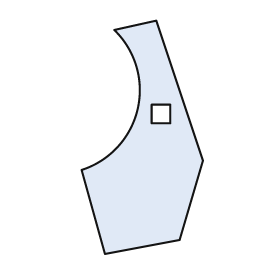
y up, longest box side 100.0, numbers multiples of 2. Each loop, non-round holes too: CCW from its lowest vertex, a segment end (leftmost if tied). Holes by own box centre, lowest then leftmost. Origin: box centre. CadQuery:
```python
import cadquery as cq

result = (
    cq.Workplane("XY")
    .moveTo(-16.0, -50.0)
    .lineTo(16.0, -44.0)
    .lineTo(26.0, -10.0)
    .lineTo(6.0, 50.0)
    .lineTo(-12.0, 46.0)
    .threePointArc((-2.0, 12.0), (-26.0, -14.0))
    .close()
    .moveTo(4.0, 6.0)
    .lineTo(12.0, 6.0)
    .lineTo(12.0, 14.0)
    .lineTo(4.0, 14.0)
    .close()
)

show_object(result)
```